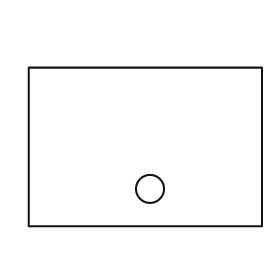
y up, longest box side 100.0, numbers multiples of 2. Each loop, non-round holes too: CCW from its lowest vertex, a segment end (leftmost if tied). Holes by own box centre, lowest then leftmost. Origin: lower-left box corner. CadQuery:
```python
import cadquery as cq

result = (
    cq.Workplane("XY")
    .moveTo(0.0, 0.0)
    .lineTo(100.0, 0.0)
    .lineTo(100.0, 68.0)
    .lineTo(0.0, 68.0)
    .close()
    .moveTo(52.0, 16.0)
    .circle(6.0)
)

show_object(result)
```